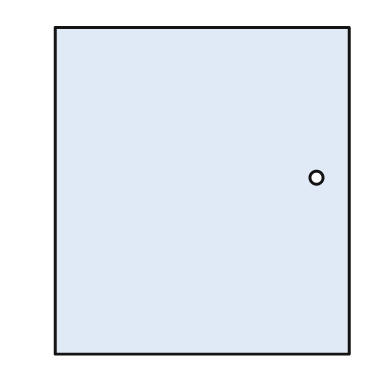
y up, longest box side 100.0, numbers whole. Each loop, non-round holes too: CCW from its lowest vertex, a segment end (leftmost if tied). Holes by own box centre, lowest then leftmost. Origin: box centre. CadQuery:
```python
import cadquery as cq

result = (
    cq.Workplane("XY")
    .moveTo(-45.0, -50.0)
    .lineTo(45.0, -50.0)
    .lineTo(45.0, 50.0)
    .lineTo(-45.0, 50.0)
    .close()
    .moveTo(35.0, 4.0)
    .circle(2.0)
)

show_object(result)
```